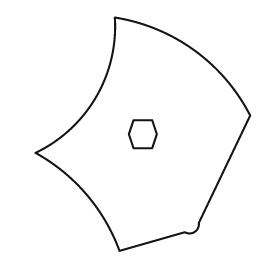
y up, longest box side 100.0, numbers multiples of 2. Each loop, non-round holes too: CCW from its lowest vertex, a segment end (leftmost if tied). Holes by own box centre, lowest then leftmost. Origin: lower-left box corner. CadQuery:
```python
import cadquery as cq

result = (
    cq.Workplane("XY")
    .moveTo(36.0, 0.0)
    .lineTo(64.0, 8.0)
    .threePointArc((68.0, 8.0), (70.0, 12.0))
    .lineTo(92.0, 58.0)
    .threePointArc((68.0, 86.0), (34.0, 100.0))
    .threePointArc((26.0, 66.0), (0.0, 42.0))
    .threePointArc((22.0, 24.0), (36.0, 0.0))
    .close()
    .moveTo(42.0, 44.0)
    .lineTo(50.0, 44.0)
    .lineTo(52.0, 50.0)
    .lineTo(50.0, 56.0)
    .lineTo(42.0, 56.0)
    .lineTo(40.0, 50.0)
    .close()
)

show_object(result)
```